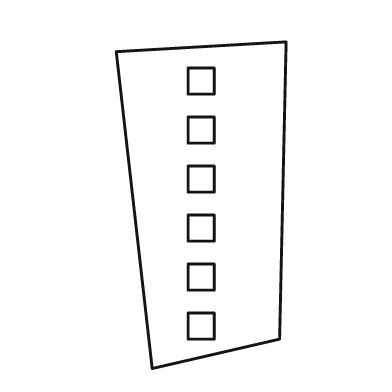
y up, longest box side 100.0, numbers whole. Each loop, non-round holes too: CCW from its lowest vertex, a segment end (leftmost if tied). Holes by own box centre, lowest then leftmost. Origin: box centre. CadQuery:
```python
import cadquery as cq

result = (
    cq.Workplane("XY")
    .moveTo(-15.0, -50.0)
    .lineTo(24.0, -41.0)
    .lineTo(26.0, 50.0)
    .lineTo(-26.0, 47.0)
    .close()
    .moveTo(-4.0, -41.0)
    .lineTo(4.0, -41.0)
    .lineTo(4.0, -33.0)
    .lineTo(-4.0, -33.0)
    .close()
    .moveTo(-4.0, -26.0)
    .lineTo(4.0, -26.0)
    .lineTo(4.0, -18.0)
    .lineTo(-4.0, -18.0)
    .close()
    .moveTo(-4.0, -11.0)
    .lineTo(4.0, -11.0)
    .lineTo(4.0, -3.0)
    .lineTo(-4.0, -3.0)
    .close()
    .moveTo(-4.0, 4.0)
    .lineTo(4.0, 4.0)
    .lineTo(4.0, 12.0)
    .lineTo(-4.0, 12.0)
    .close()
    .moveTo(-4.0, 19.0)
    .lineTo(4.0, 19.0)
    .lineTo(4.0, 27.0)
    .lineTo(-4.0, 27.0)
    .close()
    .moveTo(-4.0, 34.0)
    .lineTo(4.0, 34.0)
    .lineTo(4.0, 42.0)
    .lineTo(-4.0, 42.0)
    .close()
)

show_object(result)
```